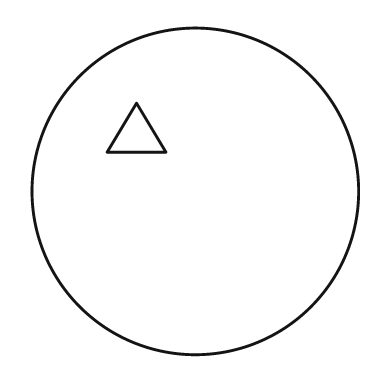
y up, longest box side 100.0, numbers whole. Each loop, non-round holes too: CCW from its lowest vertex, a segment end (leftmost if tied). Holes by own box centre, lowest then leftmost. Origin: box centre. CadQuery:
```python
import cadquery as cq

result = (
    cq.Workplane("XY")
    .moveTo(0.0, 0.0)
    .circle(50.0)
    .moveTo(-27.0, 12.0)
    .lineTo(-9.0, 12.0)
    .lineTo(-18.0, 27.0)
    .close()
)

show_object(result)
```